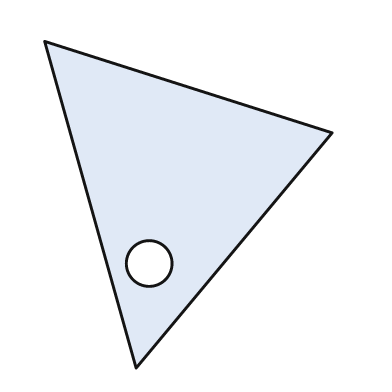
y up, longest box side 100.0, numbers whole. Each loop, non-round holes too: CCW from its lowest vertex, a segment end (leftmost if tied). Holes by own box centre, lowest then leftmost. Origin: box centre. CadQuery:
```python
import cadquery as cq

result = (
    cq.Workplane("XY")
    .moveTo(-16.0, -50.0)
    .lineTo(44.0, 22.0)
    .lineTo(-44.0, 50.0)
    .close()
    .moveTo(-12.0, -18.0)
    .circle(7.0)
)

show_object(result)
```